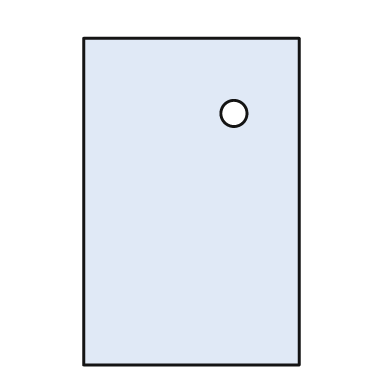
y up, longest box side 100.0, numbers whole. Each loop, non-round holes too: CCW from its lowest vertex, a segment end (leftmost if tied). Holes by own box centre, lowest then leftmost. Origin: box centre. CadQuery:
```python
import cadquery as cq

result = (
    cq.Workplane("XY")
    .moveTo(-33.0, -50.0)
    .lineTo(33.0, -50.0)
    .lineTo(33.0, 50.0)
    .lineTo(-33.0, 50.0)
    .close()
    .moveTo(13.0, 27.0)
    .circle(4.0)
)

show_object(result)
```